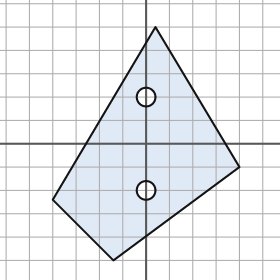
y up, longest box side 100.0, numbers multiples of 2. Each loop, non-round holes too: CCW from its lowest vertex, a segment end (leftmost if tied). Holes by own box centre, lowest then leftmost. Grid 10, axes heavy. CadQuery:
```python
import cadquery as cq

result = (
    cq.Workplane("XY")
    .moveTo(-14.0, -50.0)
    .lineTo(40.0, -10.0)
    .lineTo(4.0, 50.0)
    .lineTo(-40.0, -24.0)
    .close()
    .moveTo(0.0, -20.0)
    .circle(4.0)
    .moveTo(0.0, 20.0)
    .circle(4.0)
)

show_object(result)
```